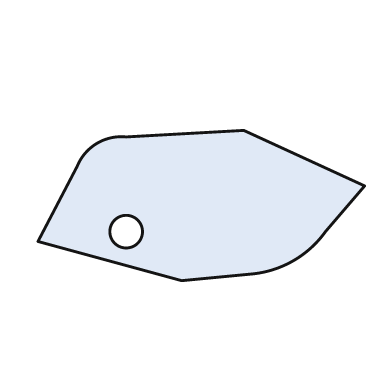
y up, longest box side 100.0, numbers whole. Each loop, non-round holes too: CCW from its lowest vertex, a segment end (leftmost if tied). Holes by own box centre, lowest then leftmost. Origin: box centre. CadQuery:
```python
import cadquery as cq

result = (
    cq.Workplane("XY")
    .moveTo(-6.0, -23.0)
    .lineTo(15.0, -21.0)
    .threePointArc((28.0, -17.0), (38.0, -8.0))
    .lineTo(50.0, 6.0)
    .lineTo(13.0, 23.0)
    .lineTo(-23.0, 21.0)
    .threePointArc((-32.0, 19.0), (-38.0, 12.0))
    .lineTo(-50.0, -11.0)
    .close()
    .moveTo(-23.0, -8.0)
    .circle(5.0)
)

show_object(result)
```